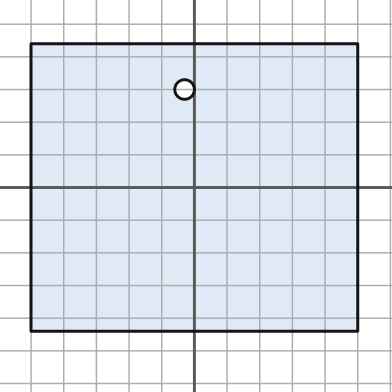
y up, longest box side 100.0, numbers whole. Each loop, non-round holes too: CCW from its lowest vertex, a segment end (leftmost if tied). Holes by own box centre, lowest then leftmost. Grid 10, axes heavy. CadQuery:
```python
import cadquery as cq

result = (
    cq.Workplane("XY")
    .moveTo(-50.0, -44.0)
    .lineTo(50.0, -44.0)
    .lineTo(50.0, 44.0)
    .lineTo(-50.0, 44.0)
    .close()
    .moveTo(-3.0, 30.0)
    .circle(3.0)
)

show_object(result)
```